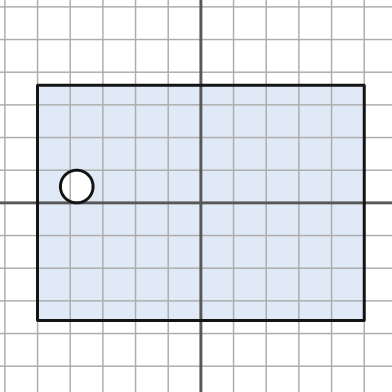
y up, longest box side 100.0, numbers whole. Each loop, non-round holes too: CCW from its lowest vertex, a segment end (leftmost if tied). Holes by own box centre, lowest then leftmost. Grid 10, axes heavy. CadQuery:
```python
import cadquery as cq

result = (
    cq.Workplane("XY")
    .moveTo(-50.0, -36.0)
    .lineTo(50.0, -36.0)
    .lineTo(50.0, 36.0)
    .lineTo(-50.0, 36.0)
    .close()
    .moveTo(-38.0, 5.0)
    .circle(5.0)
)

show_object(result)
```